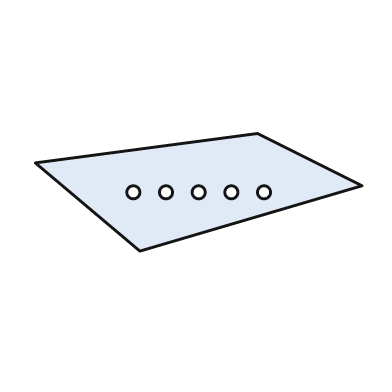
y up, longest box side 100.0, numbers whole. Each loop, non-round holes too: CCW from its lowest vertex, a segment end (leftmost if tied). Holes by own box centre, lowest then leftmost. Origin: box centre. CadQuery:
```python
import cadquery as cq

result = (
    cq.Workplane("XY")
    .moveTo(-18.0, -18.0)
    .lineTo(50.0, 2.0)
    .lineTo(18.0, 18.0)
    .lineTo(-50.0, 9.0)
    .close()
    .moveTo(-20.0, 0.0)
    .circle(2.0)
    .moveTo(-10.0, 0.0)
    .circle(2.0)
    .moveTo(0.0, 0.0)
    .circle(2.0)
    .moveTo(10.0, 0.0)
    .circle(2.0)
    .moveTo(20.0, 0.0)
    .circle(2.0)
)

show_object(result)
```